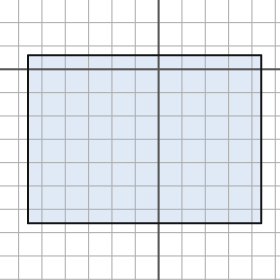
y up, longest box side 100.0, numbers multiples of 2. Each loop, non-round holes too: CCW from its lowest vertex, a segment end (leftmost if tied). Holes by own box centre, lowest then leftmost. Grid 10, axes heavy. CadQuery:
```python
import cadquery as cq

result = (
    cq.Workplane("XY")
    .moveTo(-56.0, -66.0)
    .lineTo(44.0, -66.0)
    .lineTo(44.0, 6.0)
    .lineTo(-56.0, 6.0)
    .close()
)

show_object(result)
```